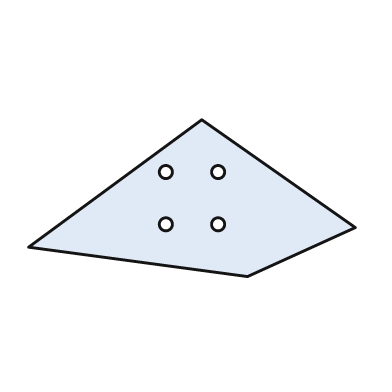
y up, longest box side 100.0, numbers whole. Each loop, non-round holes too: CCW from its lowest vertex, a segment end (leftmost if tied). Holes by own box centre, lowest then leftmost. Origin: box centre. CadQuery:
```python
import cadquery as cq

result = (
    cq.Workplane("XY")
    .moveTo(17.0, -24.0)
    .lineTo(50.0, -9.0)
    .lineTo(3.0, 24.0)
    .lineTo(-50.0, -15.0)
    .close()
    .moveTo(-8.0, -8.0)
    .circle(2.0)
    .moveTo(8.0, -8.0)
    .circle(2.0)
    .moveTo(-8.0, 8.0)
    .circle(2.0)
    .moveTo(8.0, 8.0)
    .circle(2.0)
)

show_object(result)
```